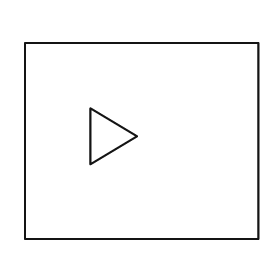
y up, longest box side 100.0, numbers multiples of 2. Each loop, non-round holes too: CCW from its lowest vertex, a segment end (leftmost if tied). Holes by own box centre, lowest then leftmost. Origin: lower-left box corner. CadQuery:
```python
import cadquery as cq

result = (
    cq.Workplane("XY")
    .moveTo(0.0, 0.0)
    .lineTo(100.0, 0.0)
    .lineTo(100.0, 84.0)
    .lineTo(0.0, 84.0)
    .close()
    .moveTo(28.0, 32.0)
    .lineTo(48.0, 44.0)
    .lineTo(28.0, 56.0)
    .close()
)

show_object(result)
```